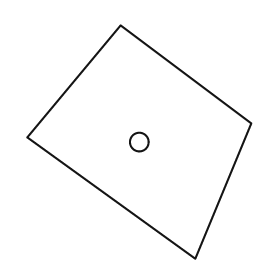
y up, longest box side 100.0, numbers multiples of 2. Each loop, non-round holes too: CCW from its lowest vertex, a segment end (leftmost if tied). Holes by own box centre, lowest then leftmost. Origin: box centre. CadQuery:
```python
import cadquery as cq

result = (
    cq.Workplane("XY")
    .moveTo(24.0, -50.0)
    .lineTo(48.0, 8.0)
    .lineTo(-8.0, 50.0)
    .lineTo(-48.0, 2.0)
    .close()
    .moveTo(0.0, 0.0)
    .circle(4.0)
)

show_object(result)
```